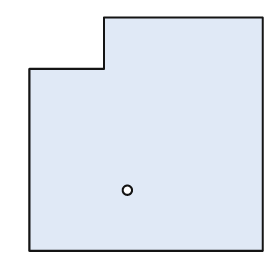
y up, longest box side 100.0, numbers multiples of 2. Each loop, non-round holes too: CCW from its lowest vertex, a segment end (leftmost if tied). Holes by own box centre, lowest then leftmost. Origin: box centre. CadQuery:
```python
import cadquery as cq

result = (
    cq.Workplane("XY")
    .moveTo(-50.0, -50.0)
    .lineTo(50.0, -50.0)
    .lineTo(50.0, 50.0)
    .lineTo(-18.0, 50.0)
    .lineTo(-18.0, 28.0)
    .lineTo(-50.0, 28.0)
    .close()
    .moveTo(-8.0, -24.0)
    .circle(2.0)
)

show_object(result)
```